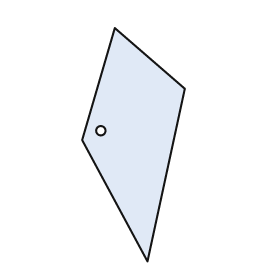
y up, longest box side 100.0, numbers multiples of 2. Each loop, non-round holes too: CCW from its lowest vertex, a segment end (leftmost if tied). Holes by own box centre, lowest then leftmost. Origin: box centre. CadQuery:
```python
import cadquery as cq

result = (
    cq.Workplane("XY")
    .moveTo(6.0, -50.0)
    .lineTo(22.0, 24.0)
    .lineTo(-8.0, 50.0)
    .lineTo(-22.0, 2.0)
    .close()
    .moveTo(-14.0, 6.0)
    .circle(2.0)
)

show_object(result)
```